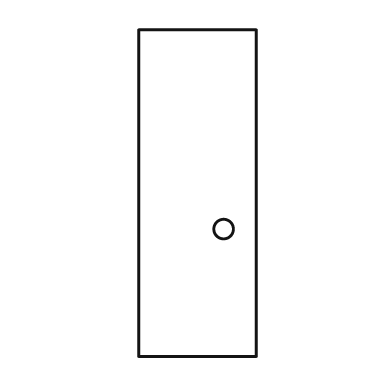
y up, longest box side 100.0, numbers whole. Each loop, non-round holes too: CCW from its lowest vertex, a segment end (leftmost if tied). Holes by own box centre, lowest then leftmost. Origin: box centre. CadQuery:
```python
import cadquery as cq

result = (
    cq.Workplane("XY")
    .moveTo(-18.0, -50.0)
    .lineTo(18.0, -50.0)
    .lineTo(18.0, 50.0)
    .lineTo(-18.0, 50.0)
    .close()
    .moveTo(8.0, -11.0)
    .circle(3.0)
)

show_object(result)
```